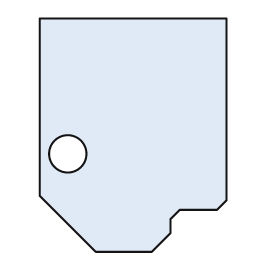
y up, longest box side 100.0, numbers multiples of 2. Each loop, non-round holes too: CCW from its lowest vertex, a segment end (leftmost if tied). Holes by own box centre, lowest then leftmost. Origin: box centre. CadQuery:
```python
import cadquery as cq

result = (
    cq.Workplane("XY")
    .moveTo(-16.0, -50.0)
    .lineTo(8.0, -50.0)
    .lineTo(16.0, -42.0)
    .lineTo(16.0, -36.0)
    .lineTo(20.0, -32.0)
    .lineTo(36.0, -32.0)
    .lineTo(40.0, -28.0)
    .lineTo(40.0, 50.0)
    .lineTo(-40.0, 50.0)
    .lineTo(-40.0, -26.0)
    .close()
    .moveTo(-28.0, -8.0)
    .circle(8.0)
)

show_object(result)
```